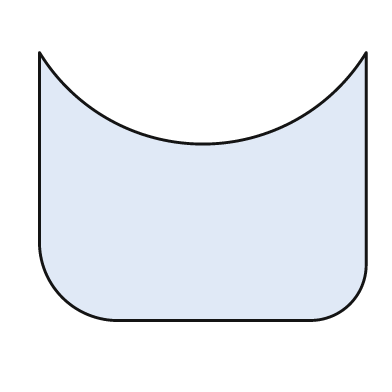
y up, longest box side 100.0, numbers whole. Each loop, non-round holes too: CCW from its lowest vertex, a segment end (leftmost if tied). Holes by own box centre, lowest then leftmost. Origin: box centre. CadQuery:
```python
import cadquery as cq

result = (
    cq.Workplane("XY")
    .moveTo(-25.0, -41.0)
    .lineTo(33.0, -41.0)
    .threePointArc((45.0, -36.0), (50.0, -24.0))
    .lineTo(50.0, 41.0)
    .threePointArc((0.0, 13.0), (-50.0, 41.0))
    .lineTo(-50.0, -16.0)
    .threePointArc((-43.0, -34.0), (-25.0, -41.0))
    .close()
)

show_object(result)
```